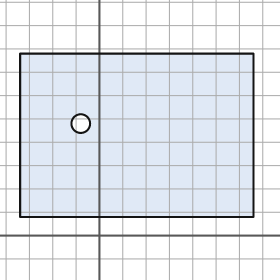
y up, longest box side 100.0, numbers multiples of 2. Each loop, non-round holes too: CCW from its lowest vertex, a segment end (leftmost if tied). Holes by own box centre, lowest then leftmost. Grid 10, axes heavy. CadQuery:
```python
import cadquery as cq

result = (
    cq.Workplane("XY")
    .moveTo(-34.0, 8.0)
    .lineTo(66.0, 8.0)
    .lineTo(66.0, 78.0)
    .lineTo(-34.0, 78.0)
    .close()
    .moveTo(-8.0, 48.0)
    .circle(4.0)
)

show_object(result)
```